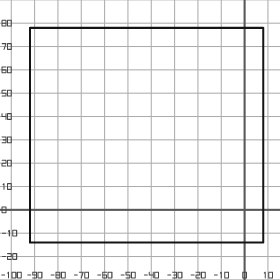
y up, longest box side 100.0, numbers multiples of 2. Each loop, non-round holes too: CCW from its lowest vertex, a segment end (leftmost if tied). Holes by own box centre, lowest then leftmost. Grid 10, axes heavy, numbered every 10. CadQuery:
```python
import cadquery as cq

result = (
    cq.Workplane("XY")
    .moveTo(-92.0, -14.0)
    .lineTo(8.0, -14.0)
    .lineTo(8.0, 78.0)
    .lineTo(-92.0, 78.0)
    .close()
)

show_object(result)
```